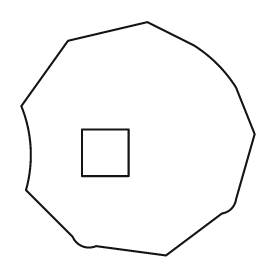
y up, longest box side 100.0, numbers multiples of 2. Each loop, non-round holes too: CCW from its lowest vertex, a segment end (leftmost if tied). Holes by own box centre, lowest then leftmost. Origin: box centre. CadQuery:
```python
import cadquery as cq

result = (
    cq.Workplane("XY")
    .moveTo(12.0, -50.0)
    .lineTo(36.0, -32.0)
    .threePointArc((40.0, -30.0), (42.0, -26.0))
    .lineTo(50.0, 2.0)
    .lineTo(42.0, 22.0)
    .threePointArc((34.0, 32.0), (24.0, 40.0))
    .lineTo(4.0, 50.0)
    .lineTo(-30.0, 42.0)
    .lineTo(-50.0, 14.0)
    .threePointArc((-46.0, -4.0), (-48.0, -22.0))
    .lineTo(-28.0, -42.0)
    .threePointArc((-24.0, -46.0), (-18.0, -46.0))
    .close()
    .moveTo(-24.0, -16.0)
    .lineTo(-4.0, -16.0)
    .lineTo(-4.0, 4.0)
    .lineTo(-24.0, 4.0)
    .close()
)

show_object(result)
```